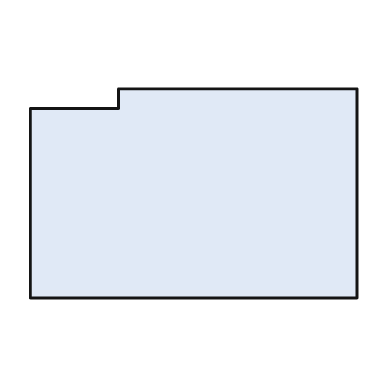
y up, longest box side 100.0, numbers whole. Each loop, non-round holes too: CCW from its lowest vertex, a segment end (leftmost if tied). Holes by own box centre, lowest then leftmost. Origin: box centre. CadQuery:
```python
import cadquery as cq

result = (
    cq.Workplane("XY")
    .moveTo(-50.0, -32.0)
    .lineTo(50.0, -32.0)
    .lineTo(50.0, 32.0)
    .lineTo(-23.0, 32.0)
    .lineTo(-23.0, 26.0)
    .lineTo(-50.0, 26.0)
    .close()
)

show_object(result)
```